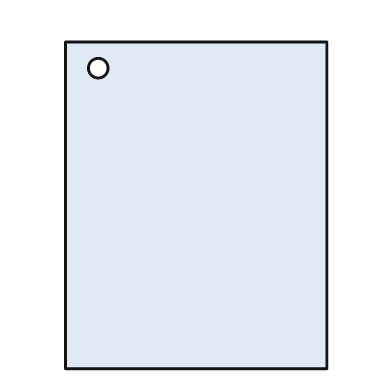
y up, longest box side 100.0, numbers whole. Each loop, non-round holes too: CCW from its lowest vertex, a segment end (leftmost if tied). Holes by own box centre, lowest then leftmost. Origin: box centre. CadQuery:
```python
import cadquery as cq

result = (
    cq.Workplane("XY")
    .moveTo(-40.0, -50.0)
    .lineTo(40.0, -50.0)
    .lineTo(40.0, 50.0)
    .lineTo(-40.0, 50.0)
    .close()
    .moveTo(-30.0, 42.0)
    .circle(3.0)
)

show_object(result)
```